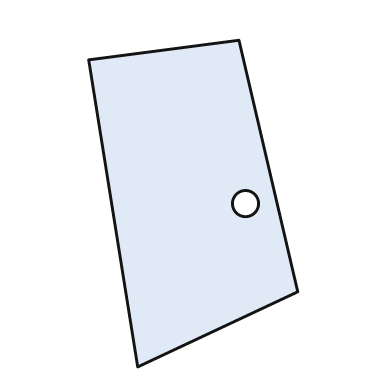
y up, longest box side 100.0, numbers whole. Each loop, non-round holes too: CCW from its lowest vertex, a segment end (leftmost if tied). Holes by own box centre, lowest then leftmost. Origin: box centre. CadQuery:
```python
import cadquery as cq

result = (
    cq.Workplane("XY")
    .moveTo(-17.0, -50.0)
    .lineTo(32.0, -27.0)
    .lineTo(14.0, 50.0)
    .lineTo(-32.0, 44.0)
    .close()
    .moveTo(16.0, 0.0)
    .circle(4.0)
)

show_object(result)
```